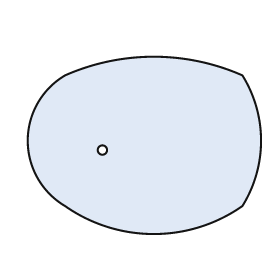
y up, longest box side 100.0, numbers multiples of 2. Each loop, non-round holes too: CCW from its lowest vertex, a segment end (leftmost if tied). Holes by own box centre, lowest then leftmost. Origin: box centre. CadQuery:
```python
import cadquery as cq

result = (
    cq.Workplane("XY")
    .moveTo(-34.0, -26.0)
    .threePointArc((4.0, -38.0), (42.0, -26.0))
    .threePointArc((50.0, 2.0), (42.0, 30.0))
    .threePointArc((4.0, 38.0), (-34.0, 30.0))
    .threePointArc((-50.0, 2.0), (-34.0, -26.0))
    .close()
    .moveTo(-18.0, -2.0)
    .circle(2.0)
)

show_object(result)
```